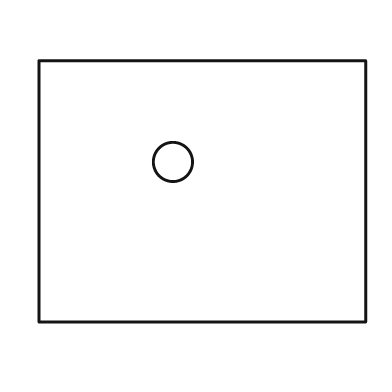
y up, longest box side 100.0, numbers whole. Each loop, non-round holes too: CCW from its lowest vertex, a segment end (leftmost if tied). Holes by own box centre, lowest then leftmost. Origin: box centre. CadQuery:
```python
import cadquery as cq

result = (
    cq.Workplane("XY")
    .moveTo(-50.0, -40.0)
    .lineTo(50.0, -40.0)
    .lineTo(50.0, 40.0)
    .lineTo(-50.0, 40.0)
    .close()
    .moveTo(-9.0, 9.0)
    .circle(6.0)
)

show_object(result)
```